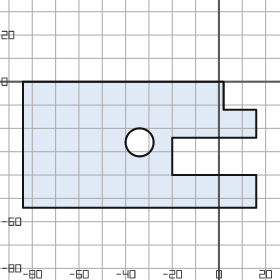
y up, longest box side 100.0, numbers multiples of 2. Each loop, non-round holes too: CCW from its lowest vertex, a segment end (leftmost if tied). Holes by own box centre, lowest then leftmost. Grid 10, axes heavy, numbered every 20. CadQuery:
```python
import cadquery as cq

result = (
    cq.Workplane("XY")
    .moveTo(-84.0, -54.0)
    .lineTo(16.0, -54.0)
    .lineTo(16.0, -40.0)
    .lineTo(-20.0, -40.0)
    .lineTo(-20.0, -24.0)
    .lineTo(16.0, -24.0)
    .lineTo(16.0, -12.0)
    .lineTo(2.0, -12.0)
    .lineTo(2.0, 0.0)
    .lineTo(-84.0, 0.0)
    .close()
    .moveTo(-34.0, -26.0)
    .circle(6.0)
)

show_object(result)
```